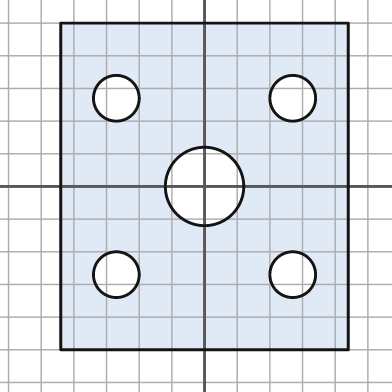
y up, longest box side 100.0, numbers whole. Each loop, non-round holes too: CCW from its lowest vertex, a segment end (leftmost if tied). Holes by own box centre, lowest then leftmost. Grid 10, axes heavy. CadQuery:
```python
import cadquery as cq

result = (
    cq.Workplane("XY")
    .moveTo(-44.0, -50.0)
    .lineTo(44.0, -50.0)
    .lineTo(44.0, 50.0)
    .lineTo(-44.0, 50.0)
    .close()
    .moveTo(-27.0, -27.0)
    .circle(7.0)
    .moveTo(27.0, -27.0)
    .circle(7.0)
    .moveTo(0.0, 0.0)
    .circle(12.0)
    .moveTo(-27.0, 27.0)
    .circle(7.0)
    .moveTo(27.0, 27.0)
    .circle(7.0)
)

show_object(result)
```